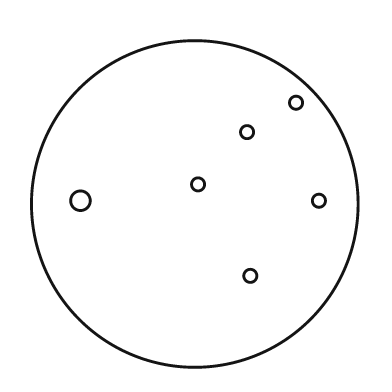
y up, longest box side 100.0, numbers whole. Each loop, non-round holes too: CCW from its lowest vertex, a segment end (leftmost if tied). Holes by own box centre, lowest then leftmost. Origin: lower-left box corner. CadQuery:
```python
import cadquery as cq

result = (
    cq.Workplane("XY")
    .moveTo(50.0, 50.0)
    .circle(50.0)
    .moveTo(67.0, 28.0)
    .circle(2.0)
    .moveTo(15.0, 51.0)
    .circle(3.0)
    .moveTo(88.0, 51.0)
    .circle(2.0)
    .moveTo(51.0, 56.0)
    .circle(2.0)
    .moveTo(66.0, 72.0)
    .circle(2.0)
    .moveTo(81.0, 81.0)
    .circle(2.0)
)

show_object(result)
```